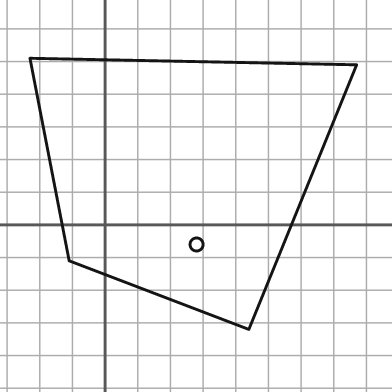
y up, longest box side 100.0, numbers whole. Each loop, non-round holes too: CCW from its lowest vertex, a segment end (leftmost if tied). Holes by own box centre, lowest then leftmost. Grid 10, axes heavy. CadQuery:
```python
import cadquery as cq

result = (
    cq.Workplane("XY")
    .moveTo(44.0, -32.0)
    .lineTo(77.0, 49.0)
    .lineTo(-23.0, 51.0)
    .lineTo(-11.0, -11.0)
    .close()
    .moveTo(28.0, -6.0)
    .circle(2.0)
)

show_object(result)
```